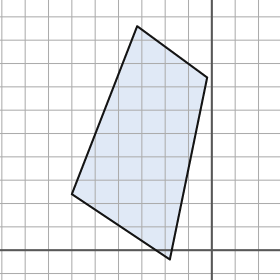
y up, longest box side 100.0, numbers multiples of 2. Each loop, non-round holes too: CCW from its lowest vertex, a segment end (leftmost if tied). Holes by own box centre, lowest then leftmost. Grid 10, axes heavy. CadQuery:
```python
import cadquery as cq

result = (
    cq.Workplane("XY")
    .moveTo(-18.0, -4.0)
    .lineTo(-2.0, 74.0)
    .lineTo(-32.0, 96.0)
    .lineTo(-60.0, 24.0)
    .close()
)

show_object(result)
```